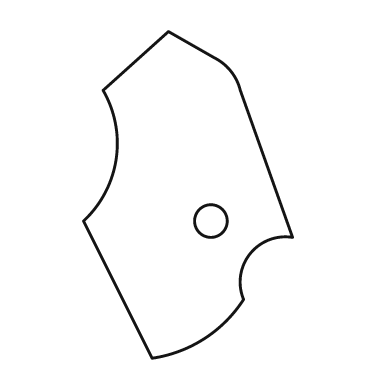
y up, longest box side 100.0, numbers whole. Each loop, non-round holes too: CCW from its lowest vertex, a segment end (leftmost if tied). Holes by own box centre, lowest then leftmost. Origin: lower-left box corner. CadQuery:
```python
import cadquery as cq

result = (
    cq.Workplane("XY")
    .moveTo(21.0, 0.0)
    .threePointArc((37.0, 6.0), (49.0, 18.0))
    .threePointArc((51.0, 32.0), (64.0, 37.0))
    .lineTo(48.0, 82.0)
    .threePointArc((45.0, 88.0), (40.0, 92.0))
    .lineTo(26.0, 100.0)
    .lineTo(6.0, 82.0)
    .threePointArc((10.0, 61.0), (0.0, 42.0))
    .close()
    .moveTo(39.0, 42.0)
    .circle(5.0)
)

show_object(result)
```